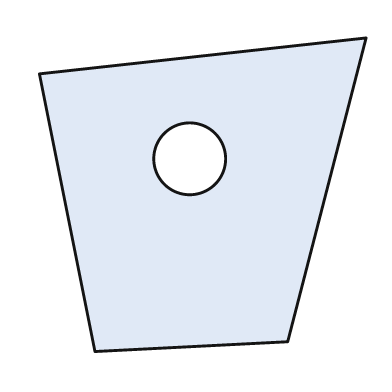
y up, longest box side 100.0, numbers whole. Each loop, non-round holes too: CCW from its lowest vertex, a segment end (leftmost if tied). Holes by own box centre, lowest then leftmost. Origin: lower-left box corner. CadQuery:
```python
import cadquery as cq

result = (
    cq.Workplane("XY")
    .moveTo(17.0, 0.0)
    .lineTo(76.0, 3.0)
    .lineTo(100.0, 96.0)
    .lineTo(0.0, 85.0)
    .close()
    .moveTo(46.0, 59.0)
    .circle(11.0)
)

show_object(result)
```